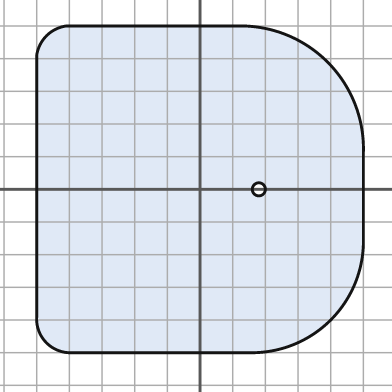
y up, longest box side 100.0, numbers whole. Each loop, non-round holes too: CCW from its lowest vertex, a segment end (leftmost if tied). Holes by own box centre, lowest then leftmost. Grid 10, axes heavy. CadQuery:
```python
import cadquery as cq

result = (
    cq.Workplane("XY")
    .moveTo(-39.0, -50.0)
    .lineTo(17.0, -50.0)
    .threePointArc((40.0, -40.0), (50.0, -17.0))
    .lineTo(50.0, 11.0)
    .threePointArc((39.0, 39.0), (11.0, 50.0))
    .lineTo(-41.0, 50.0)
    .threePointArc((-47.0, 47.0), (-50.0, 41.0))
    .lineTo(-50.0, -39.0)
    .threePointArc((-47.0, -47.0), (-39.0, -50.0))
    .close()
    .moveTo(18.0, 0.0)
    .circle(2.0)
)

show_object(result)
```